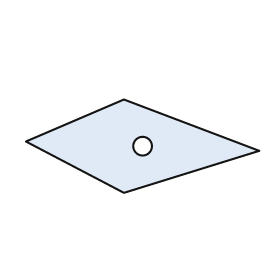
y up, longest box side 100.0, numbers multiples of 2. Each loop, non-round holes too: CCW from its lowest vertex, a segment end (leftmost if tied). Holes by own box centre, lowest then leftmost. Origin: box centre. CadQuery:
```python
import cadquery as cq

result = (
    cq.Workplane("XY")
    .moveTo(-8.0, -20.0)
    .lineTo(50.0, -2.0)
    .lineTo(-8.0, 20.0)
    .lineTo(-50.0, 2.0)
    .close()
    .moveTo(0.0, 0.0)
    .circle(4.0)
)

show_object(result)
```